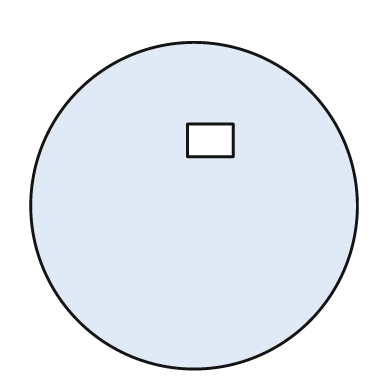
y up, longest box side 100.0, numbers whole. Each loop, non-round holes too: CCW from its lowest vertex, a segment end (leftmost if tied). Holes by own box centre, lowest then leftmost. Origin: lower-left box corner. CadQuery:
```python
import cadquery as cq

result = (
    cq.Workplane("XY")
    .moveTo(50.0, 50.0)
    .circle(50.0)
    .moveTo(48.0, 65.0)
    .lineTo(62.0, 65.0)
    .lineTo(62.0, 75.0)
    .lineTo(48.0, 75.0)
    .close()
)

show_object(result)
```